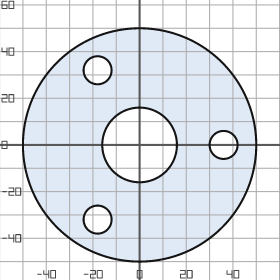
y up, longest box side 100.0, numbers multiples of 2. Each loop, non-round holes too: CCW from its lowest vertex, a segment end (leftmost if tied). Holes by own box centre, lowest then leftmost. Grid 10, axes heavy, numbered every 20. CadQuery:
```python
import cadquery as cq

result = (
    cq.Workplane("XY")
    .moveTo(0.0, 0.0)
    .circle(50.0)
    .moveTo(-18.0, -32.0)
    .circle(6.0)
    .moveTo(0.0, 0.0)
    .circle(16.0)
    .moveTo(36.0, 0.0)
    .circle(6.0)
    .moveTo(-18.0, 32.0)
    .circle(6.0)
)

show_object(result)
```